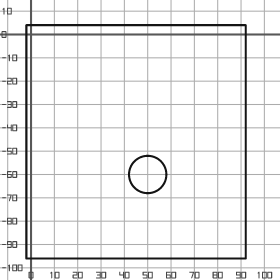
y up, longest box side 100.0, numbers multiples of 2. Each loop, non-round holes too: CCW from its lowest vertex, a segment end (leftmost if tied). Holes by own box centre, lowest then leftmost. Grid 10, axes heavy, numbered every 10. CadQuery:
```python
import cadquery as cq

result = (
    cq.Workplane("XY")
    .moveTo(-2.0, -96.0)
    .lineTo(92.0, -96.0)
    .lineTo(92.0, 4.0)
    .lineTo(-2.0, 4.0)
    .close()
    .moveTo(50.0, -60.0)
    .circle(8.0)
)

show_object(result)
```